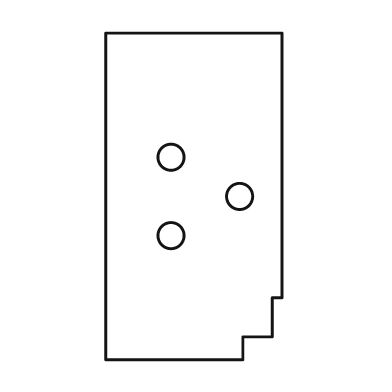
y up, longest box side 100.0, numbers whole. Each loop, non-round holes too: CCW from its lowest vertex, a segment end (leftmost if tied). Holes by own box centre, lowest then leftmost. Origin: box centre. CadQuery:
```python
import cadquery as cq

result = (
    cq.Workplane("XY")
    .moveTo(-27.0, -50.0)
    .lineTo(15.0, -50.0)
    .lineTo(15.0, -43.0)
    .lineTo(24.0, -43.0)
    .lineTo(24.0, -31.0)
    .lineTo(27.0, -31.0)
    .lineTo(27.0, 50.0)
    .lineTo(-27.0, 50.0)
    .close()
    .moveTo(-7.0, -12.0)
    .circle(4.0)
    .moveTo(14.0, 0.0)
    .circle(4.0)
    .moveTo(-7.0, 12.0)
    .circle(4.0)
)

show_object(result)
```